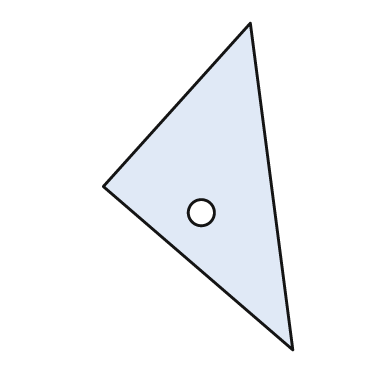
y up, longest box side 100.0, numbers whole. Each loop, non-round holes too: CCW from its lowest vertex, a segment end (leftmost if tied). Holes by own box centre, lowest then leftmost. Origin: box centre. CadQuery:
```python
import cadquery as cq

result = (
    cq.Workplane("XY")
    .moveTo(29.0, -50.0)
    .lineTo(16.0, 50.0)
    .lineTo(-29.0, 0.0)
    .close()
    .moveTo(1.0, -8.0)
    .circle(4.0)
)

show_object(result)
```